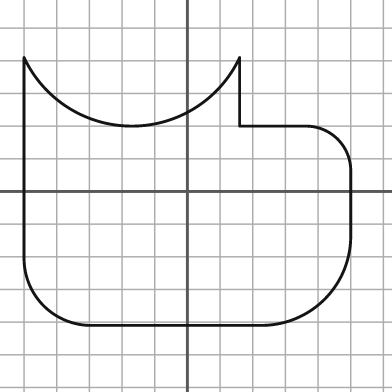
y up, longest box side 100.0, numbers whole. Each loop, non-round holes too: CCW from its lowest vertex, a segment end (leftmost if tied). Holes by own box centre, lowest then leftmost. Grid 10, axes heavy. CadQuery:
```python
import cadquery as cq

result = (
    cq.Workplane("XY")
    .moveTo(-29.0, -41.0)
    .lineTo(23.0, -41.0)
    .threePointArc((42.0, -33.0), (50.0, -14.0))
    .lineTo(50.0, 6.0)
    .threePointArc((46.0, 16.0), (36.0, 20.0))
    .lineTo(16.0, 20.0)
    .lineTo(16.0, 41.0)
    .threePointArc((-17.0, 20.0), (-50.0, 41.0))
    .lineTo(-50.0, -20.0)
    .threePointArc((-44.0, -35.0), (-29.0, -41.0))
    .close()
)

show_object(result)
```